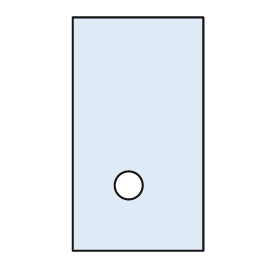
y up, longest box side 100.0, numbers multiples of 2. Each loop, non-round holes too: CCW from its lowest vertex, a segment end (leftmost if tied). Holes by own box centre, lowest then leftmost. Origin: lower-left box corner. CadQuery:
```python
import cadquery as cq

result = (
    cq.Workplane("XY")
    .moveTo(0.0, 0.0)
    .lineTo(56.0, 0.0)
    .lineTo(56.0, 100.0)
    .lineTo(0.0, 100.0)
    .close()
    .moveTo(24.0, 28.0)
    .circle(6.0)
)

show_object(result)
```